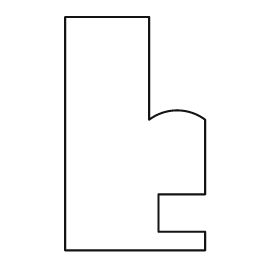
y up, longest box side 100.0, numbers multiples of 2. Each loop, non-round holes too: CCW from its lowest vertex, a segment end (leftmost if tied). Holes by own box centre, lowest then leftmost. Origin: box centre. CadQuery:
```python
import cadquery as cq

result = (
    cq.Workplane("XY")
    .moveTo(-30.0, -50.0)
    .lineTo(30.0, -50.0)
    .lineTo(30.0, -42.0)
    .lineTo(10.0, -42.0)
    .lineTo(10.0, -26.0)
    .lineTo(30.0, -26.0)
    .lineTo(30.0, 6.0)
    .threePointArc((18.0, 10.0), (6.0, 6.0))
    .lineTo(6.0, 50.0)
    .lineTo(-30.0, 50.0)
    .close()
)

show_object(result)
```